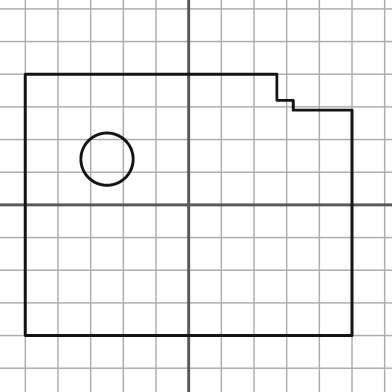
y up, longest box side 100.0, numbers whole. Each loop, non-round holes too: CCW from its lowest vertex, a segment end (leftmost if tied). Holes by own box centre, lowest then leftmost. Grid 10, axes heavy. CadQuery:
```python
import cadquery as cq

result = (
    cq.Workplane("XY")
    .moveTo(-50.0, -40.0)
    .lineTo(50.0, -40.0)
    .lineTo(50.0, 29.0)
    .lineTo(32.0, 29.0)
    .lineTo(32.0, 32.0)
    .lineTo(27.0, 32.0)
    .lineTo(27.0, 40.0)
    .lineTo(-50.0, 40.0)
    .close()
    .moveTo(-25.0, 14.0)
    .circle(8.0)
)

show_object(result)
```